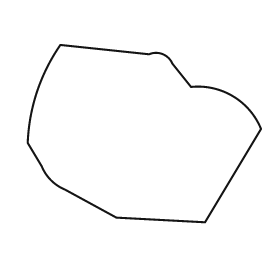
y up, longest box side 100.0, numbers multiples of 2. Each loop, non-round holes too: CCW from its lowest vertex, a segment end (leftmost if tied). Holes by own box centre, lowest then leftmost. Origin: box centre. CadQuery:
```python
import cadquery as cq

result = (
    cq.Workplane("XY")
    .moveTo(26.0, -38.0)
    .lineTo(50.0, 2.0)
    .threePointArc((38.0, 16.0), (20.0, 20.0))
    .lineTo(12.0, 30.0)
    .threePointArc((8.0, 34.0), (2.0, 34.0))
    .lineTo(-36.0, 38.0)
    .threePointArc((-46.0, 18.0), (-50.0, -4.0))
    .lineTo(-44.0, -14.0)
    .threePointArc((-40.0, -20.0), (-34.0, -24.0))
    .lineTo(-12.0, -36.0)
    .close()
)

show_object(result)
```